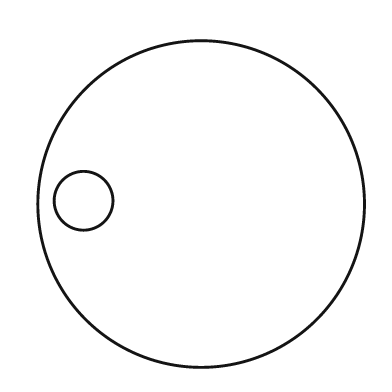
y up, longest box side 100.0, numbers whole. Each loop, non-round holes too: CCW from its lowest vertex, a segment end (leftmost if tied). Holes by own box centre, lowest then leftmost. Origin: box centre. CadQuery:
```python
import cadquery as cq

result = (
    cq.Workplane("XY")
    .moveTo(0.0, 0.0)
    .circle(50.0)
    .moveTo(-36.0, 1.0)
    .circle(9.0)
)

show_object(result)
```